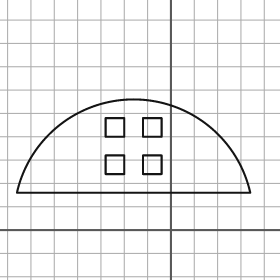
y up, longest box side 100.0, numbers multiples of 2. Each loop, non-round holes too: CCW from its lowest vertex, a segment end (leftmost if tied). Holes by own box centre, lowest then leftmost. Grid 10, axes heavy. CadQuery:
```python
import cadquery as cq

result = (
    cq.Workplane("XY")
    .moveTo(-66.0, 16.0)
    .lineTo(34.0, 16.0)
    .threePointArc((-16.0, 56.0), (-66.0, 16.0))
    .close()
    .moveTo(-28.0, 24.0)
    .lineTo(-20.0, 24.0)
    .lineTo(-20.0, 32.0)
    .lineTo(-28.0, 32.0)
    .close()
    .moveTo(-12.0, 24.0)
    .lineTo(-4.0, 24.0)
    .lineTo(-4.0, 32.0)
    .lineTo(-12.0, 32.0)
    .close()
    .moveTo(-28.0, 40.0)
    .lineTo(-20.0, 40.0)
    .lineTo(-20.0, 48.0)
    .lineTo(-28.0, 48.0)
    .close()
    .moveTo(-12.0, 40.0)
    .lineTo(-4.0, 40.0)
    .lineTo(-4.0, 48.0)
    .lineTo(-12.0, 48.0)
    .close()
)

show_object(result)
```